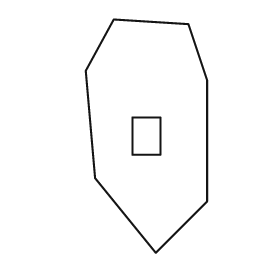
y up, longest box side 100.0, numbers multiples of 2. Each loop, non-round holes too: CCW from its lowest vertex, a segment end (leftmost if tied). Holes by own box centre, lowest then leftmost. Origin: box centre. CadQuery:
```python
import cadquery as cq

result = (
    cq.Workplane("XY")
    .moveTo(4.0, -50.0)
    .lineTo(26.0, -28.0)
    .lineTo(26.0, 24.0)
    .lineTo(18.0, 48.0)
    .lineTo(-14.0, 50.0)
    .lineTo(-26.0, 28.0)
    .lineTo(-22.0, -18.0)
    .close()
    .moveTo(-6.0, -8.0)
    .lineTo(6.0, -8.0)
    .lineTo(6.0, 8.0)
    .lineTo(-6.0, 8.0)
    .close()
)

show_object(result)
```